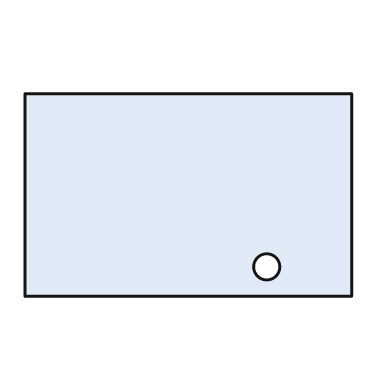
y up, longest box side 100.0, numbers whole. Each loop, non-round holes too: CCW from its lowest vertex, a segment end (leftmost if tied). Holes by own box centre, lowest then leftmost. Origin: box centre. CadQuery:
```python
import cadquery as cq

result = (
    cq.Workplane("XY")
    .moveTo(-50.0, -31.0)
    .lineTo(50.0, -31.0)
    .lineTo(50.0, 31.0)
    .lineTo(-50.0, 31.0)
    .close()
    .moveTo(24.0, -22.0)
    .circle(4.0)
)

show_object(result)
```